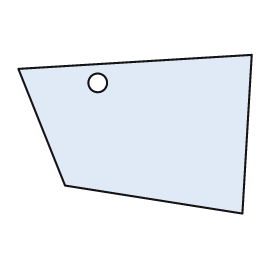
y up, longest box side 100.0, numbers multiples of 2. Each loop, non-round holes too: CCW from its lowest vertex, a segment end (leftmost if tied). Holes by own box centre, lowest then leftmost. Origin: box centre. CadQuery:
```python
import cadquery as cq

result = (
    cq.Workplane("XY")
    .moveTo(46.0, -34.0)
    .lineTo(50.0, 34.0)
    .lineTo(-50.0, 28.0)
    .lineTo(-30.0, -22.0)
    .close()
    .moveTo(-16.0, 22.0)
    .circle(4.0)
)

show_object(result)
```